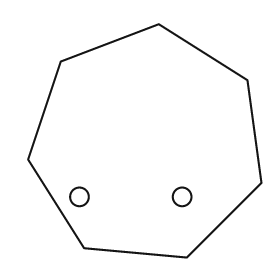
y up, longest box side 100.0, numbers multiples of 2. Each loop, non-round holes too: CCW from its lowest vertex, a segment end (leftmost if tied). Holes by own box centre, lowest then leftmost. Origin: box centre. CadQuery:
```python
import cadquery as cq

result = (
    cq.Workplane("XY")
    .moveTo(18.0, -50.0)
    .lineTo(50.0, -18.0)
    .lineTo(44.0, 26.0)
    .lineTo(6.0, 50.0)
    .lineTo(-36.0, 34.0)
    .lineTo(-50.0, -8.0)
    .lineTo(-26.0, -46.0)
    .close()
    .moveTo(-28.0, -24.0)
    .circle(4.0)
    .moveTo(16.0, -24.0)
    .circle(4.0)
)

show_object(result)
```